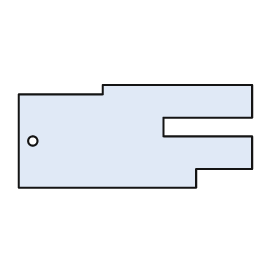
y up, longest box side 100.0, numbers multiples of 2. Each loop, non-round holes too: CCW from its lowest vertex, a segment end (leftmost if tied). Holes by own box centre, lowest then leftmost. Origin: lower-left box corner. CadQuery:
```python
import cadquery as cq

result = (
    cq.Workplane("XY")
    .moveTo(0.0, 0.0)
    .lineTo(76.0, 0.0)
    .lineTo(76.0, 8.0)
    .lineTo(100.0, 8.0)
    .lineTo(100.0, 22.0)
    .lineTo(62.0, 22.0)
    .lineTo(62.0, 30.0)
    .lineTo(100.0, 30.0)
    .lineTo(100.0, 44.0)
    .lineTo(36.0, 44.0)
    .lineTo(36.0, 40.0)
    .lineTo(0.0, 40.0)
    .close()
    .moveTo(6.0, 20.0)
    .circle(2.0)
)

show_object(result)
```